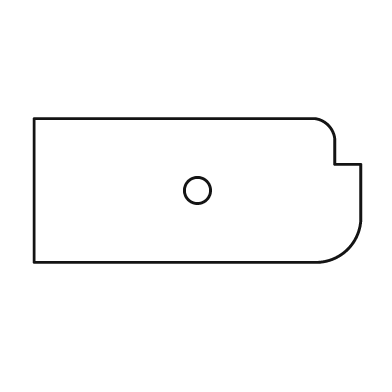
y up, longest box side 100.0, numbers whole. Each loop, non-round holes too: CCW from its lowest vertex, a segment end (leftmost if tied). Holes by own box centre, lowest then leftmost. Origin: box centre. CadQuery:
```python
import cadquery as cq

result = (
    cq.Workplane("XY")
    .moveTo(-50.0, -22.0)
    .lineTo(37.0, -22.0)
    .threePointArc((46.0, -18.0), (50.0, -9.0))
    .lineTo(50.0, 8.0)
    .lineTo(42.0, 8.0)
    .lineTo(42.0, 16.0)
    .threePointArc((40.0, 20.0), (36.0, 22.0))
    .lineTo(-50.0, 22.0)
    .close()
    .moveTo(0.0, 0.0)
    .circle(4.0)
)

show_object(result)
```